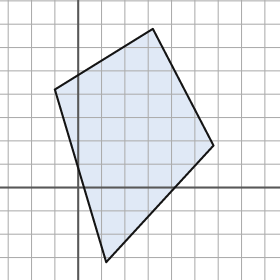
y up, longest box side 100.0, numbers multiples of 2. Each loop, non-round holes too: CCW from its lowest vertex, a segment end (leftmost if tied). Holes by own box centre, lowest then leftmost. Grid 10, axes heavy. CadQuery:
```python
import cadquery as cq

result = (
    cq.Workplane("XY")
    .moveTo(12.0, -32.0)
    .lineTo(58.0, 18.0)
    .lineTo(32.0, 68.0)
    .lineTo(-10.0, 42.0)
    .close()
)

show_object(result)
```